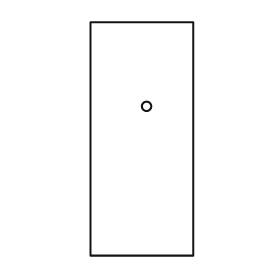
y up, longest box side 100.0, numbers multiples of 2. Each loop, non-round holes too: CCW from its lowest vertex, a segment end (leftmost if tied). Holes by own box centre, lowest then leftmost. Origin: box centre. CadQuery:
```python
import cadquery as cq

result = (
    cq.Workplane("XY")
    .moveTo(-22.0, -50.0)
    .lineTo(22.0, -50.0)
    .lineTo(22.0, 50.0)
    .lineTo(-22.0, 50.0)
    .close()
    .moveTo(2.0, 14.0)
    .circle(2.0)
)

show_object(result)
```